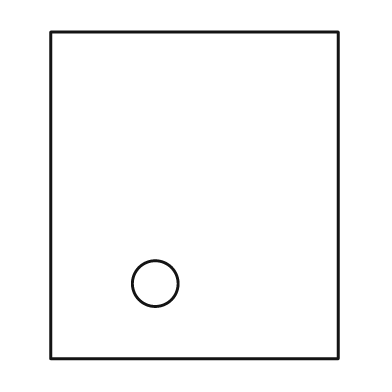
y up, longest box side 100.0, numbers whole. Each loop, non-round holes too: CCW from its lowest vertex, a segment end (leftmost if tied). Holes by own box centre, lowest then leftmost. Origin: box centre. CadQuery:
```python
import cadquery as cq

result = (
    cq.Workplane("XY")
    .moveTo(-44.0, -50.0)
    .lineTo(44.0, -50.0)
    .lineTo(44.0, 50.0)
    .lineTo(-44.0, 50.0)
    .close()
    .moveTo(-12.0, -27.0)
    .circle(7.0)
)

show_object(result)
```